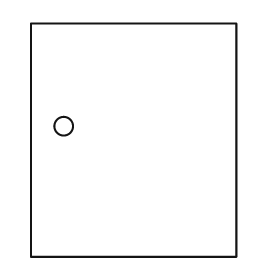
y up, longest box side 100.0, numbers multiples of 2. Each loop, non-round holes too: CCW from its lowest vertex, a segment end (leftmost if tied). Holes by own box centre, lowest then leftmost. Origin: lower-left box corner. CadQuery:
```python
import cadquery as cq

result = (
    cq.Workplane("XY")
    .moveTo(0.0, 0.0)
    .lineTo(88.0, 0.0)
    .lineTo(88.0, 100.0)
    .lineTo(0.0, 100.0)
    .close()
    .moveTo(14.0, 56.0)
    .circle(4.0)
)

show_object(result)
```